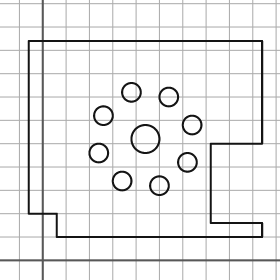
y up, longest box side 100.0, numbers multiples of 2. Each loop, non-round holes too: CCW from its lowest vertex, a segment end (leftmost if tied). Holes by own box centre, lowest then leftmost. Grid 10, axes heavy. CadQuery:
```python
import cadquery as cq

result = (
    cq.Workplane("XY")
    .moveTo(6.0, 10.0)
    .lineTo(94.0, 10.0)
    .lineTo(94.0, 16.0)
    .lineTo(72.0, 16.0)
    .lineTo(72.0, 50.0)
    .lineTo(94.0, 50.0)
    .lineTo(94.0, 94.0)
    .lineTo(-6.0, 94.0)
    .lineTo(-6.0, 20.0)
    .lineTo(6.0, 20.0)
    .close()
    .moveTo(50.0, 32.0)
    .circle(4.0)
    .moveTo(34.0, 34.0)
    .circle(4.0)
    .moveTo(62.0, 42.0)
    .circle(4.0)
    .moveTo(24.0, 46.0)
    .circle(4.0)
    .moveTo(44.0, 52.0)
    .circle(6.0)
    .moveTo(64.0, 58.0)
    .circle(4.0)
    .moveTo(26.0, 62.0)
    .circle(4.0)
    .moveTo(54.0, 70.0)
    .circle(4.0)
    .moveTo(38.0, 72.0)
    .circle(4.0)
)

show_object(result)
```